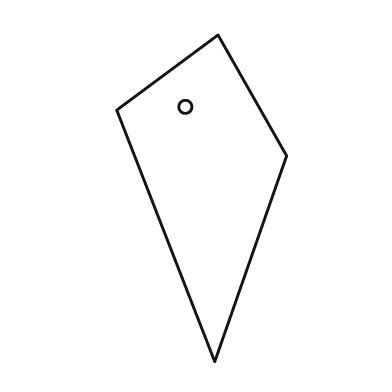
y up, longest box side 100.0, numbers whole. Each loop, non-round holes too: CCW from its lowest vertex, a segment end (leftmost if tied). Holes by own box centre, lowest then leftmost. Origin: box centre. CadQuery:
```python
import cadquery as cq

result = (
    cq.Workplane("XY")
    .moveTo(4.0, -50.0)
    .lineTo(26.0, 13.0)
    .lineTo(5.0, 50.0)
    .lineTo(-26.0, 27.0)
    .close()
    .moveTo(-5.0, 28.0)
    .circle(2.0)
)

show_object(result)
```